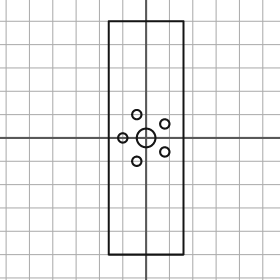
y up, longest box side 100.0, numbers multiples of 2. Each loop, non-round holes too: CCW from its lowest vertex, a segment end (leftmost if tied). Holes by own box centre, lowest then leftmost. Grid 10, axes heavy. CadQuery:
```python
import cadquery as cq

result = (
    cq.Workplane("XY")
    .moveTo(-16.0, -50.0)
    .lineTo(16.0, -50.0)
    .lineTo(16.0, 50.0)
    .lineTo(-16.0, 50.0)
    .close()
    .moveTo(-4.0, -10.0)
    .circle(2.0)
    .moveTo(8.0, -6.0)
    .circle(2.0)
    .moveTo(-10.0, 0.0)
    .circle(2.0)
    .moveTo(0.0, 0.0)
    .circle(4.0)
    .moveTo(8.0, 6.0)
    .circle(2.0)
    .moveTo(-4.0, 10.0)
    .circle(2.0)
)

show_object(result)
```